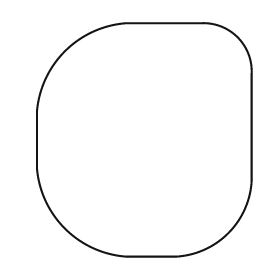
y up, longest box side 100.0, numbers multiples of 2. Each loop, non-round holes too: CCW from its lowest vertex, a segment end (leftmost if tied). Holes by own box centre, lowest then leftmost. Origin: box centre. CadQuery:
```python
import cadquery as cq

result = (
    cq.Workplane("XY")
    .moveTo(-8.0, -50.0)
    .lineTo(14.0, -50.0)
    .threePointArc((36.0, -40.0), (46.0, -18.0))
    .lineTo(46.0, 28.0)
    .threePointArc((40.0, 44.0), (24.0, 50.0))
    .lineTo(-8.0, 50.0)
    .threePointArc((-34.0, 38.0), (-46.0, 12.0))
    .lineTo(-46.0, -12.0)
    .threePointArc((-34.0, -38.0), (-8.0, -50.0))
    .close()
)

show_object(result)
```